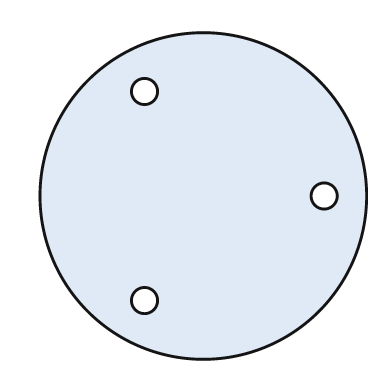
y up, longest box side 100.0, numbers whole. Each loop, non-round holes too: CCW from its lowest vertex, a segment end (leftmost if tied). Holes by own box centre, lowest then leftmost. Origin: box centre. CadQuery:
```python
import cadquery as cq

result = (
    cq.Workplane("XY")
    .moveTo(0.0, 0.0)
    .circle(50.0)
    .moveTo(-18.0, -32.0)
    .circle(4.0)
    .moveTo(37.0, 0.0)
    .circle(4.0)
    .moveTo(-18.0, 32.0)
    .circle(4.0)
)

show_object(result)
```